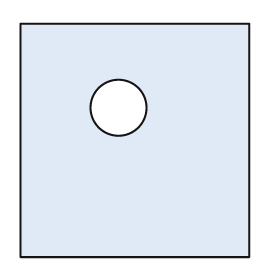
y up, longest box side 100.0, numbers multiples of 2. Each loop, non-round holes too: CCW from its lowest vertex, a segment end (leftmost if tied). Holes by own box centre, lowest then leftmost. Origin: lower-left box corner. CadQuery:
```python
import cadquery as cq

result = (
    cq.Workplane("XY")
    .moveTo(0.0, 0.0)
    .lineTo(98.0, 0.0)
    .lineTo(98.0, 100.0)
    .lineTo(0.0, 100.0)
    .close()
    .moveTo(42.0, 64.0)
    .circle(12.0)
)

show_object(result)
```